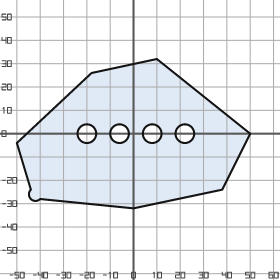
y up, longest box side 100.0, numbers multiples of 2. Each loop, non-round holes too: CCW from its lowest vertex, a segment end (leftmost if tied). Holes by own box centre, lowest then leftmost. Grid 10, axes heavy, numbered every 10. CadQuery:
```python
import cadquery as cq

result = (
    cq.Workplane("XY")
    .moveTo(0.0, -32.0)
    .lineTo(38.0, -24.0)
    .lineTo(50.0, 0.0)
    .lineTo(10.0, 32.0)
    .lineTo(-18.0, 26.0)
    .lineTo(-50.0, -4.0)
    .lineTo(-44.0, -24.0)
    .threePointArc((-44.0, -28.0), (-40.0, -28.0))
    .close()
    .moveTo(-20.0, 0.0)
    .circle(4.0)
    .moveTo(-6.0, 0.0)
    .circle(4.0)
    .moveTo(8.0, 0.0)
    .circle(4.0)
    .moveTo(22.0, 0.0)
    .circle(4.0)
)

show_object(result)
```